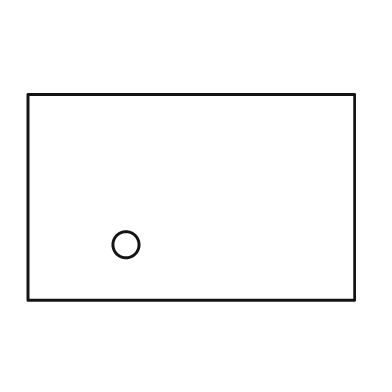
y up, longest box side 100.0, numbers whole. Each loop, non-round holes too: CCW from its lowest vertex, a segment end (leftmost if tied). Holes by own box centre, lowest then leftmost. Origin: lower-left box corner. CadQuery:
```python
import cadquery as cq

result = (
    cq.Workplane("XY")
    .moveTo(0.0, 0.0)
    .lineTo(100.0, 0.0)
    .lineTo(100.0, 63.0)
    .lineTo(0.0, 63.0)
    .close()
    .moveTo(30.0, 17.0)
    .circle(4.0)
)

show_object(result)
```